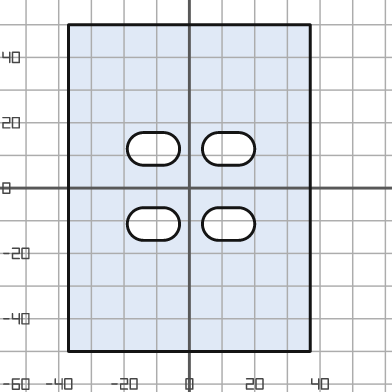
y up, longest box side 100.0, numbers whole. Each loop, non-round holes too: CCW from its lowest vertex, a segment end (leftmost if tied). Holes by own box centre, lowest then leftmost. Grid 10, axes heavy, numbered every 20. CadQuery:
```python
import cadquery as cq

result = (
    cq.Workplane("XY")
    .moveTo(-37.0, -50.0)
    .lineTo(37.0, -50.0)
    .lineTo(37.0, 50.0)
    .lineTo(-37.0, 50.0)
    .close()
    .moveTo(-14.0, -16.0)
    .lineTo(-8.0, -16.0)
    .threePointArc((-3.0, -11.0), (-8.0, -6.0))
    .lineTo(-14.0, -6.0)
    .threePointArc((-19.0, -11.0), (-14.0, -16.0))
    .close()
    .moveTo(9.0, -16.0)
    .lineTo(15.0, -16.0)
    .threePointArc((20.0, -11.0), (15.0, -6.0))
    .lineTo(9.0, -6.0)
    .threePointArc((4.0, -11.0), (9.0, -16.0))
    .close()
    .moveTo(-14.0, 7.0)
    .lineTo(-8.0, 7.0)
    .threePointArc((-3.0, 12.0), (-8.0, 17.0))
    .lineTo(-14.0, 17.0)
    .threePointArc((-19.0, 12.0), (-14.0, 7.0))
    .close()
    .moveTo(9.0, 7.0)
    .lineTo(15.0, 7.0)
    .threePointArc((20.0, 12.0), (15.0, 17.0))
    .lineTo(9.0, 17.0)
    .threePointArc((4.0, 12.0), (9.0, 7.0))
    .close()
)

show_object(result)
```